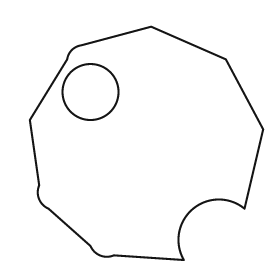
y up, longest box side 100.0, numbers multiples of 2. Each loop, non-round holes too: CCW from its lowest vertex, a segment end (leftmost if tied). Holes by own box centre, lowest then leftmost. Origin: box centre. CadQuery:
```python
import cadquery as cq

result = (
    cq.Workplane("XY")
    .moveTo(16.0, -50.0)
    .threePointArc((20.0, -28.0), (42.0, -28.0))
    .lineTo(50.0, 6.0)
    .lineTo(34.0, 36.0)
    .lineTo(2.0, 50.0)
    .lineTo(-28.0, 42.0)
    .threePointArc((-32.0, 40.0), (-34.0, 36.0))
    .lineTo(-50.0, 10.0)
    .lineTo(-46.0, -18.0)
    .threePointArc((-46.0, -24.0), (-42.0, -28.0))
    .lineTo(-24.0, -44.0)
    .threePointArc((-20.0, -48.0), (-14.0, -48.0))
    .close()
    .moveTo(-24.0, 22.0)
    .circle(12.0)
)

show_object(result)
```